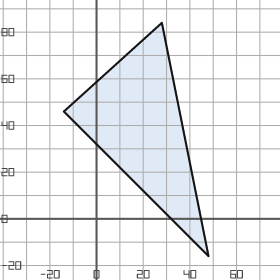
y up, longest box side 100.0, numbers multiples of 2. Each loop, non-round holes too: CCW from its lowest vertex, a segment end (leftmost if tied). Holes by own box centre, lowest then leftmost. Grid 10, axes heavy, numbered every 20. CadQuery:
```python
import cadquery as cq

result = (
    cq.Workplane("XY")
    .moveTo(48.0, -16.0)
    .lineTo(28.0, 84.0)
    .lineTo(-14.0, 46.0)
    .close()
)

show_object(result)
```